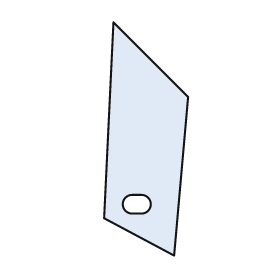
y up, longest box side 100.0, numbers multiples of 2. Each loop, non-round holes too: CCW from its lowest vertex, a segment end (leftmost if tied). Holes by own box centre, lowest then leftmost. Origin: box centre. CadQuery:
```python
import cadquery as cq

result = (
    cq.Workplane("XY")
    .moveTo(12.0, -50.0)
    .lineTo(18.0, 18.0)
    .lineTo(-14.0, 50.0)
    .lineTo(-18.0, -34.0)
    .close()
    .moveTo(-6.0, -32.0)
    .lineTo(-2.0, -32.0)
    .threePointArc((2.0, -28.0), (-2.0, -24.0))
    .lineTo(-6.0, -24.0)
    .threePointArc((-10.0, -28.0), (-6.0, -32.0))
    .close()
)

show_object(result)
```